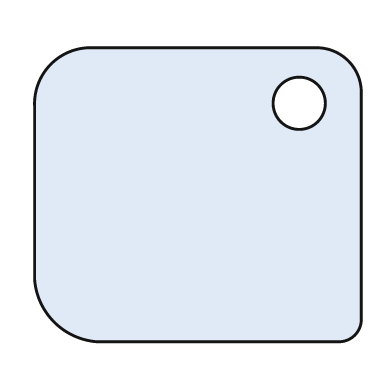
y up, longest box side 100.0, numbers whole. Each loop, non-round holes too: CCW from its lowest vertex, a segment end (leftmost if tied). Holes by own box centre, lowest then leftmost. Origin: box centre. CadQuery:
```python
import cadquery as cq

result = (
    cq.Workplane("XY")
    .moveTo(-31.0, -45.0)
    .lineTo(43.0, -45.0)
    .threePointArc((48.0, -43.0), (50.0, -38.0))
    .lineTo(50.0, 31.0)
    .threePointArc((46.0, 41.0), (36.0, 45.0))
    .lineTo(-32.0, 45.0)
    .threePointArc((-45.0, 40.0), (-50.0, 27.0))
    .lineTo(-50.0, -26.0)
    .threePointArc((-44.0, -39.0), (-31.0, -45.0))
    .close()
    .moveTo(31.0, 28.0)
    .circle(8.0)
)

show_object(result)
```